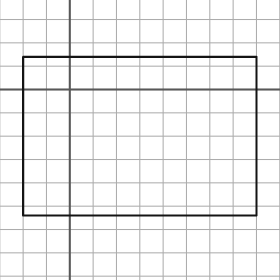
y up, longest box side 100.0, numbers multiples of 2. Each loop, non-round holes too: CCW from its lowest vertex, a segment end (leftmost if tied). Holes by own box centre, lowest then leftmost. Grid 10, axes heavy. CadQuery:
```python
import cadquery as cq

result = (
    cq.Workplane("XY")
    .moveTo(-20.0, -54.0)
    .lineTo(80.0, -54.0)
    .lineTo(80.0, 14.0)
    .lineTo(-20.0, 14.0)
    .close()
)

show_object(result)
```